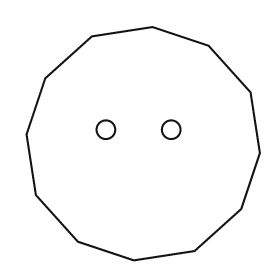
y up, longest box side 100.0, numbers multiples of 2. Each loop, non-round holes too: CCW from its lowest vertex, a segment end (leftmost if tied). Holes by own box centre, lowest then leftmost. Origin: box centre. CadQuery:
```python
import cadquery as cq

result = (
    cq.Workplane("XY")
    .moveTo(-4.0, -50.0)
    .lineTo(22.0, -46.0)
    .lineTo(42.0, -28.0)
    .lineTo(50.0, -4.0)
    .lineTo(46.0, 22.0)
    .lineTo(28.0, 42.0)
    .lineTo(4.0, 50.0)
    .lineTo(-22.0, 46.0)
    .lineTo(-42.0, 28.0)
    .lineTo(-50.0, 4.0)
    .lineTo(-46.0, -22.0)
    .lineTo(-28.0, -42.0)
    .close()
    .moveTo(-16.0, 6.0)
    .circle(4.0)
    .moveTo(12.0, 6.0)
    .circle(4.0)
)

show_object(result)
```